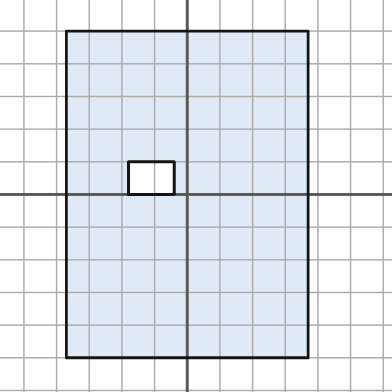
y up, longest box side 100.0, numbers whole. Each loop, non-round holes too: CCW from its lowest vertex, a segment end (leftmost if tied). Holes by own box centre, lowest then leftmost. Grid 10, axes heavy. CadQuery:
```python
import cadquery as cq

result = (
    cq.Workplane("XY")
    .moveTo(-37.0, -50.0)
    .lineTo(37.0, -50.0)
    .lineTo(37.0, 50.0)
    .lineTo(-37.0, 50.0)
    .close()
    .moveTo(-18.0, 0.0)
    .lineTo(-4.0, 0.0)
    .lineTo(-4.0, 10.0)
    .lineTo(-18.0, 10.0)
    .close()
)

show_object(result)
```